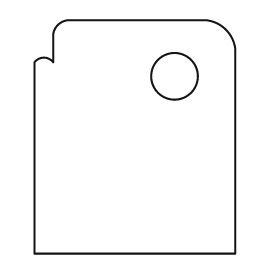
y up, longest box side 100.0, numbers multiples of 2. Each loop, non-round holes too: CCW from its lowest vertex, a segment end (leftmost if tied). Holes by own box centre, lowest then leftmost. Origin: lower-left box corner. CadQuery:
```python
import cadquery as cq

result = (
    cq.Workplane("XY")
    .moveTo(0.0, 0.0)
    .lineTo(86.0, 0.0)
    .lineTo(86.0, 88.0)
    .threePointArc((82.0, 96.0), (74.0, 100.0))
    .lineTo(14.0, 100.0)
    .threePointArc((10.0, 98.0), (8.0, 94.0))
    .lineTo(8.0, 82.0)
    .threePointArc((4.0, 84.0), (0.0, 82.0))
    .close()
    .moveTo(60.0, 76.0)
    .circle(10.0)
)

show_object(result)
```